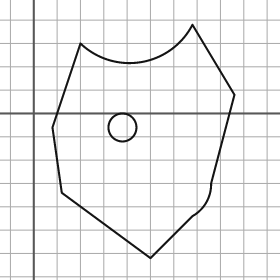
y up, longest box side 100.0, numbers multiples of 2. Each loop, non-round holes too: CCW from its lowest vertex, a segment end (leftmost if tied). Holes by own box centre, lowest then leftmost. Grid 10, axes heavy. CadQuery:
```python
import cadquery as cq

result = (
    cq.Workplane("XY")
    .moveTo(50.0, -62.0)
    .lineTo(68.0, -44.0)
    .threePointArc((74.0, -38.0), (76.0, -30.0))
    .lineTo(86.0, 8.0)
    .lineTo(68.0, 38.0)
    .threePointArc((46.0, 22.0), (20.0, 30.0))
    .lineTo(8.0, -6.0)
    .lineTo(12.0, -34.0)
    .close()
    .moveTo(38.0, -6.0)
    .circle(6.0)
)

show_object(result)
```